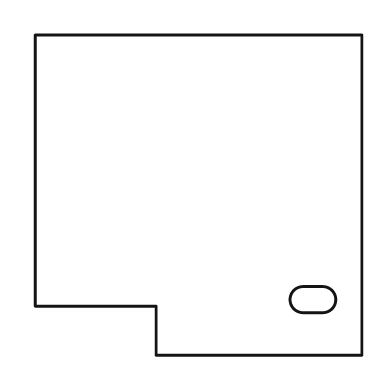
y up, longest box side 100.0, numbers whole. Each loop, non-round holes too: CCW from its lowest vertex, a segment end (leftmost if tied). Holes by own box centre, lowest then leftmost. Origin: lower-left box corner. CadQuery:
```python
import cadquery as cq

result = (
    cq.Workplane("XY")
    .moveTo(37.0, 0.0)
    .lineTo(100.0, 0.0)
    .lineTo(100.0, 98.0)
    .lineTo(0.0, 98.0)
    .lineTo(0.0, 15.0)
    .lineTo(37.0, 15.0)
    .close()
    .moveTo(82.0, 13.0)
    .lineTo(88.0, 13.0)
    .threePointArc((92.0, 17.0), (88.0, 21.0))
    .lineTo(82.0, 21.0)
    .threePointArc((78.0, 17.0), (82.0, 13.0))
    .close()
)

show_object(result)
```